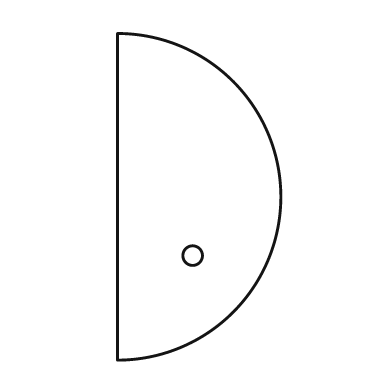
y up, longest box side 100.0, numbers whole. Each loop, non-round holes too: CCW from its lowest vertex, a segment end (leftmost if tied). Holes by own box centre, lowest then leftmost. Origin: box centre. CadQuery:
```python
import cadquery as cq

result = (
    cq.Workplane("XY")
    .moveTo(-25.0, -50.0)
    .threePointArc((25.0, 0.0), (-25.0, 50.0))
    .close()
    .moveTo(-2.0, -18.0)
    .circle(3.0)
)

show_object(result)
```